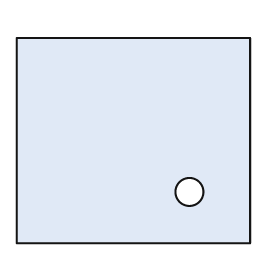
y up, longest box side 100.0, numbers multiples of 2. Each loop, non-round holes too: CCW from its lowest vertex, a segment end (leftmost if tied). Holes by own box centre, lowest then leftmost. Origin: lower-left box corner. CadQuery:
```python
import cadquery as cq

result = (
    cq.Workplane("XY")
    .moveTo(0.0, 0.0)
    .lineTo(100.0, 0.0)
    .lineTo(100.0, 88.0)
    .lineTo(0.0, 88.0)
    .close()
    .moveTo(74.0, 22.0)
    .circle(6.0)
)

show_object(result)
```